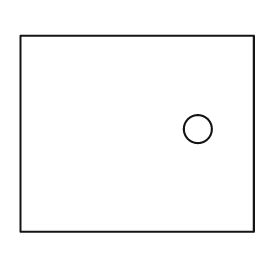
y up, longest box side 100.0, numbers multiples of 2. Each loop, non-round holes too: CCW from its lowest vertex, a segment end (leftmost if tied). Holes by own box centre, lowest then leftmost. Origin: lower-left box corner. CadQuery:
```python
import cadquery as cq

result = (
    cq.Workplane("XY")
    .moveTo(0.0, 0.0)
    .lineTo(100.0, 0.0)
    .lineTo(100.0, 84.0)
    .lineTo(0.0, 84.0)
    .close()
    .moveTo(76.0, 44.0)
    .circle(6.0)
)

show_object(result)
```